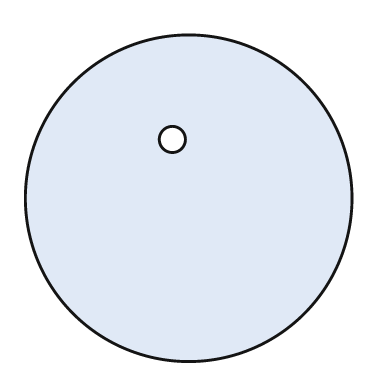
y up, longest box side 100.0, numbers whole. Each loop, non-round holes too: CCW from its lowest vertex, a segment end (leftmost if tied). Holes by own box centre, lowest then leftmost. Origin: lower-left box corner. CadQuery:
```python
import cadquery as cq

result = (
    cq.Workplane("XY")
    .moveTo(50.0, 50.0)
    .circle(50.0)
    .moveTo(45.0, 68.0)
    .circle(4.0)
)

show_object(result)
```